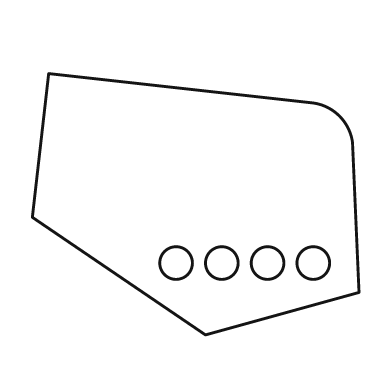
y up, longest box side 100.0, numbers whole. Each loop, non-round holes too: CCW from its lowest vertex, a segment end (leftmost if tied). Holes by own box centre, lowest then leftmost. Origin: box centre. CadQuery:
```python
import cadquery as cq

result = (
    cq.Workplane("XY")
    .moveTo(3.0, -40.0)
    .lineTo(50.0, -27.0)
    .lineTo(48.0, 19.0)
    .threePointArc((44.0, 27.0), (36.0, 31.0))
    .lineTo(-45.0, 40.0)
    .lineTo(-50.0, -4.0)
    .close()
    .moveTo(-6.0, -18.0)
    .circle(5.0)
    .moveTo(8.0, -18.0)
    .circle(5.0)
    .moveTo(22.0, -18.0)
    .circle(5.0)
    .moveTo(36.0, -18.0)
    .circle(5.0)
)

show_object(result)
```